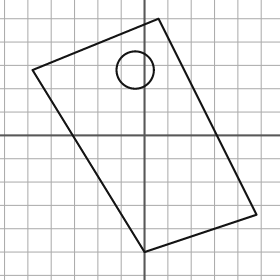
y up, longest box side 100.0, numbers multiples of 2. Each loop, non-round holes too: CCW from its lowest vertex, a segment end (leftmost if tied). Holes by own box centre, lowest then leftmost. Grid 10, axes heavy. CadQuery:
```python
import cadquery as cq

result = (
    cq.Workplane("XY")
    .moveTo(0.0, -50.0)
    .lineTo(48.0, -34.0)
    .lineTo(6.0, 50.0)
    .lineTo(-48.0, 28.0)
    .close()
    .moveTo(-4.0, 28.0)
    .circle(8.0)
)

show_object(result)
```